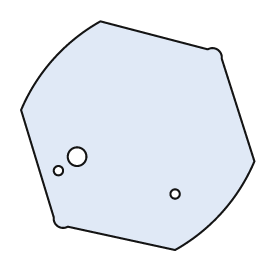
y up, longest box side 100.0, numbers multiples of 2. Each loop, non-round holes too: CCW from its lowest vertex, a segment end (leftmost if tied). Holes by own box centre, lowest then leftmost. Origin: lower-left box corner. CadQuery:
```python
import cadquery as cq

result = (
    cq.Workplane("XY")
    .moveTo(66.0, 0.0)
    .threePointArc((86.0, 16.0), (100.0, 38.0))
    .lineTo(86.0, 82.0)
    .threePointArc((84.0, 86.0), (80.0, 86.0))
    .lineTo(34.0, 98.0)
    .threePointArc((14.0, 82.0), (0.0, 60.0))
    .lineTo(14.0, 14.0)
    .threePointArc((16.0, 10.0), (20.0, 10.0))
    .close()
    .moveTo(66.0, 24.0)
    .circle(2.0)
    .moveTo(16.0, 34.0)
    .circle(2.0)
    .moveTo(24.0, 40.0)
    .circle(4.0)
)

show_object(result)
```